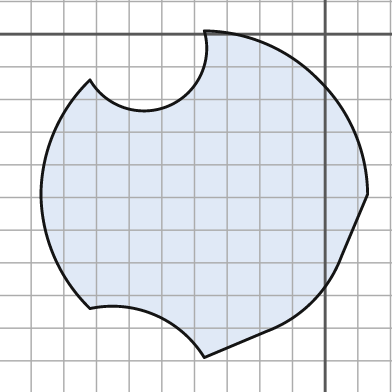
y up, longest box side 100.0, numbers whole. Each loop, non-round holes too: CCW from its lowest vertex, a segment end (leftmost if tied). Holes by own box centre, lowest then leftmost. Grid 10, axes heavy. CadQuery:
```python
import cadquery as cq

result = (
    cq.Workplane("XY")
    .moveTo(-37.0, -99.0)
    .lineTo(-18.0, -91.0)
    .threePointArc((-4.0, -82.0), (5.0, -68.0))
    .lineTo(13.0, -49.0)
    .threePointArc((9.0, -30.0), (-2.0, -14.0))
    .threePointArc((-18.0, -3.0), (-37.0, 1.0))
    .threePointArc((-48.0, -22.0), (-72.0, -14.0))
    .threePointArc((-83.0, -30.0), (-87.0, -49.0))
    .threePointArc((-83.0, -68.0), (-72.0, -84.0))
    .threePointArc((-52.0, -86.0), (-37.0, -99.0))
    .close()
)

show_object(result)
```